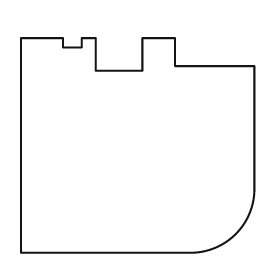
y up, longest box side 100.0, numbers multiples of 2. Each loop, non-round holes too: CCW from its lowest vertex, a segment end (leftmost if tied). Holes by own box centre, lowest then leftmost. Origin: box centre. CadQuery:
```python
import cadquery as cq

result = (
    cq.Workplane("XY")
    .moveTo(-50.0, -46.0)
    .lineTo(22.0, -46.0)
    .threePointArc((42.0, -38.0), (50.0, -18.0))
    .lineTo(50.0, 34.0)
    .lineTo(16.0, 34.0)
    .lineTo(16.0, 46.0)
    .lineTo(2.0, 46.0)
    .lineTo(2.0, 32.0)
    .lineTo(-18.0, 32.0)
    .lineTo(-18.0, 46.0)
    .lineTo(-24.0, 46.0)
    .lineTo(-24.0, 42.0)
    .lineTo(-32.0, 42.0)
    .lineTo(-32.0, 46.0)
    .lineTo(-50.0, 46.0)
    .close()
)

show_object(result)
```